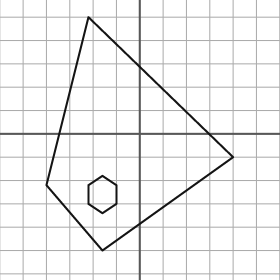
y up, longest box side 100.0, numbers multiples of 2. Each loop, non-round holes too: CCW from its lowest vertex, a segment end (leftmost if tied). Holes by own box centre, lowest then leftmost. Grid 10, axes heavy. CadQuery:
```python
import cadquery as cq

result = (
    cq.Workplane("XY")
    .moveTo(-16.0, -50.0)
    .lineTo(40.0, -10.0)
    .lineTo(-22.0, 50.0)
    .lineTo(-40.0, -22.0)
    .close()
    .moveTo(-16.0, -34.0)
    .lineTo(-10.0, -30.0)
    .lineTo(-10.0, -22.0)
    .lineTo(-16.0, -18.0)
    .lineTo(-22.0, -22.0)
    .lineTo(-22.0, -30.0)
    .close()
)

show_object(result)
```